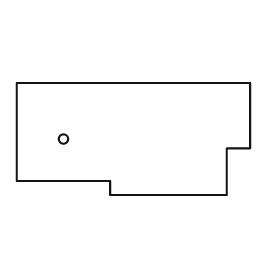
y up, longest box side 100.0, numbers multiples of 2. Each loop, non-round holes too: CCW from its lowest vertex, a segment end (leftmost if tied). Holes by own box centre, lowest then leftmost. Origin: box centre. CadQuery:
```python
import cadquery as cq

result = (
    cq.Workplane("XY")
    .moveTo(-10.0, -24.0)
    .lineTo(40.0, -24.0)
    .lineTo(40.0, -4.0)
    .lineTo(50.0, -4.0)
    .lineTo(50.0, 24.0)
    .lineTo(-50.0, 24.0)
    .lineTo(-50.0, -18.0)
    .lineTo(-10.0, -18.0)
    .close()
    .moveTo(-30.0, 0.0)
    .circle(2.0)
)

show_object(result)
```